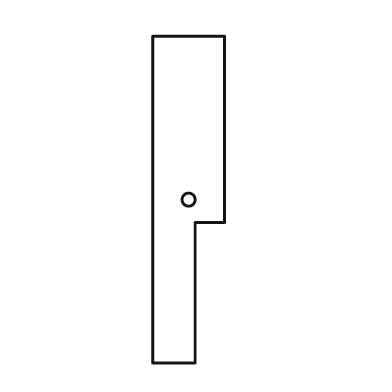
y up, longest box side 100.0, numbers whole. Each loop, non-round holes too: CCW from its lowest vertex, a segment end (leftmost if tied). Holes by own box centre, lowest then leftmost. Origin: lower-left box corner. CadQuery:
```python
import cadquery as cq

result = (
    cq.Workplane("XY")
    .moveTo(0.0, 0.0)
    .lineTo(13.0, 0.0)
    .lineTo(13.0, 43.0)
    .lineTo(22.0, 43.0)
    .lineTo(22.0, 100.0)
    .lineTo(0.0, 100.0)
    .close()
    .moveTo(11.0, 50.0)
    .circle(2.0)
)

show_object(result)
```